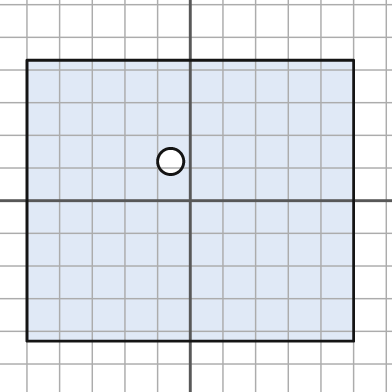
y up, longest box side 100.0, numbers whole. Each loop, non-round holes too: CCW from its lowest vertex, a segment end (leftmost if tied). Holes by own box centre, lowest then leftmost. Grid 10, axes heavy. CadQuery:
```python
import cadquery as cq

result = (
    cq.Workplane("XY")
    .moveTo(-50.0, -43.0)
    .lineTo(50.0, -43.0)
    .lineTo(50.0, 43.0)
    .lineTo(-50.0, 43.0)
    .close()
    .moveTo(-6.0, 12.0)
    .circle(4.0)
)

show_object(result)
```